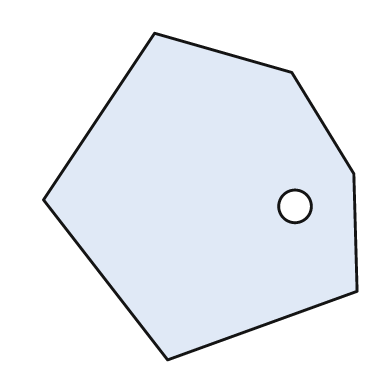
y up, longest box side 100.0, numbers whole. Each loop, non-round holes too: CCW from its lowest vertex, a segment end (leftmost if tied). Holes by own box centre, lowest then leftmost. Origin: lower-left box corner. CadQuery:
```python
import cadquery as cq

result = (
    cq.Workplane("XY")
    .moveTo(38.0, 0.0)
    .lineTo(96.0, 21.0)
    .lineTo(95.0, 57.0)
    .lineTo(76.0, 88.0)
    .lineTo(34.0, 100.0)
    .lineTo(0.0, 49.0)
    .close()
    .moveTo(77.0, 47.0)
    .circle(5.0)
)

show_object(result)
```